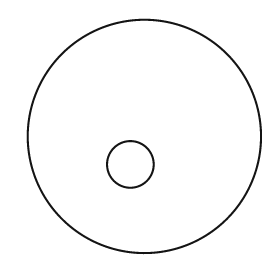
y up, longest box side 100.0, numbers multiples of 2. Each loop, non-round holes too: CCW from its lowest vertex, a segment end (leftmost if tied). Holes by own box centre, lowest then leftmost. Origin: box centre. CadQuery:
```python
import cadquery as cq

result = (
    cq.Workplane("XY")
    .moveTo(0.0, 0.0)
    .circle(50.0)
    .moveTo(-6.0, -12.0)
    .circle(10.0)
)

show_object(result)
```